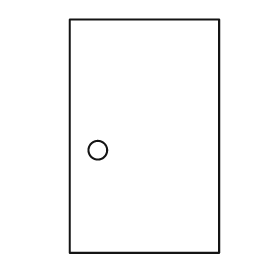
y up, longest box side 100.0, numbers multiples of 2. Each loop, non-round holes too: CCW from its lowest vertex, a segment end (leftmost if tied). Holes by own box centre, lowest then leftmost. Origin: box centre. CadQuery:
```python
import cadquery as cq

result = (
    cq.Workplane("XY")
    .moveTo(-32.0, -50.0)
    .lineTo(32.0, -50.0)
    .lineTo(32.0, 50.0)
    .lineTo(-32.0, 50.0)
    .close()
    .moveTo(-20.0, -6.0)
    .circle(4.0)
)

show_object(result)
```